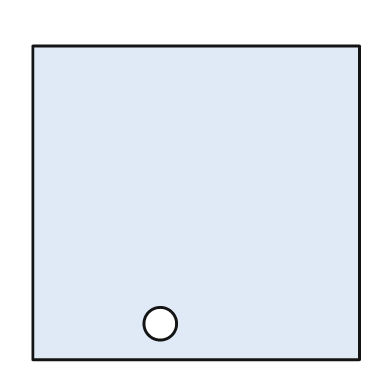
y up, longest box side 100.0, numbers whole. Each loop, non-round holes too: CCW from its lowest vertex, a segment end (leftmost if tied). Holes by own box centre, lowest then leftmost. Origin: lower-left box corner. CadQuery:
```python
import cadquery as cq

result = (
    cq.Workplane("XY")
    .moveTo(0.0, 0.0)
    .lineTo(100.0, 0.0)
    .lineTo(100.0, 96.0)
    .lineTo(0.0, 96.0)
    .close()
    .moveTo(39.0, 11.0)
    .circle(5.0)
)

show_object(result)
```